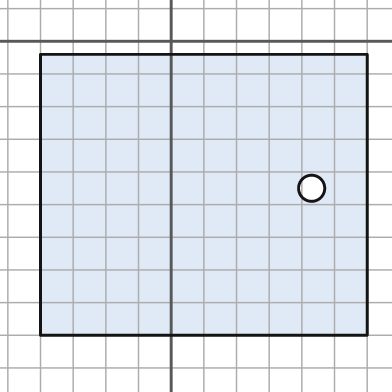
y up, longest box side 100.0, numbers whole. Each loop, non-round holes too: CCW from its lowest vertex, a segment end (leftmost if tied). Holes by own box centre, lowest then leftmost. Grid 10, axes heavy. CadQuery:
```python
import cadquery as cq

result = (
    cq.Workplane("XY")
    .moveTo(-40.0, -90.0)
    .lineTo(60.0, -90.0)
    .lineTo(60.0, -4.0)
    .lineTo(-40.0, -4.0)
    .close()
    .moveTo(43.0, -45.0)
    .circle(4.0)
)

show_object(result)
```